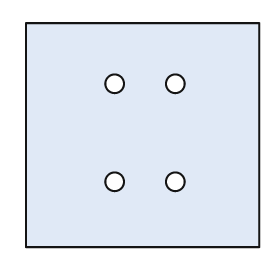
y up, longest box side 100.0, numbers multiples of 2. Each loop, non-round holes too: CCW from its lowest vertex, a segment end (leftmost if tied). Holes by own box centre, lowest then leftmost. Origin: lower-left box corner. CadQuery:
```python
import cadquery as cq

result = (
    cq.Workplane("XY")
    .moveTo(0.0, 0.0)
    .lineTo(100.0, 0.0)
    .lineTo(100.0, 96.0)
    .lineTo(0.0, 96.0)
    .close()
    .moveTo(38.0, 28.0)
    .circle(4.0)
    .moveTo(64.0, 28.0)
    .circle(4.0)
    .moveTo(38.0, 70.0)
    .circle(4.0)
    .moveTo(64.0, 70.0)
    .circle(4.0)
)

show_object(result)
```